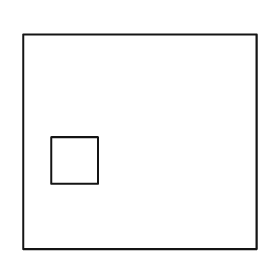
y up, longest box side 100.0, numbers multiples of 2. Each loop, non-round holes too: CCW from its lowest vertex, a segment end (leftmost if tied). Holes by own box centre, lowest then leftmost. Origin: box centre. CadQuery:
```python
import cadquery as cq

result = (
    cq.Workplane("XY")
    .moveTo(-50.0, -46.0)
    .lineTo(50.0, -46.0)
    .lineTo(50.0, 46.0)
    .lineTo(-50.0, 46.0)
    .close()
    .moveTo(-38.0, -18.0)
    .lineTo(-18.0, -18.0)
    .lineTo(-18.0, 2.0)
    .lineTo(-38.0, 2.0)
    .close()
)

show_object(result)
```